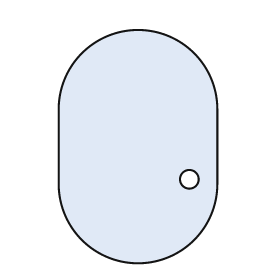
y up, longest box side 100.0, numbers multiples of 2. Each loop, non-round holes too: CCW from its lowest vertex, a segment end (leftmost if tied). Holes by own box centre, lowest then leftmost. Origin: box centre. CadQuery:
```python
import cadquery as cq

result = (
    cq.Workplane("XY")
    .moveTo(-34.0, -16.0)
    .threePointArc((0.0, -50.0), (34.0, -16.0))
    .lineTo(34.0, 16.0)
    .threePointArc((0.0, 50.0), (-34.0, 16.0))
    .close()
    .moveTo(22.0, -14.0)
    .circle(4.0)
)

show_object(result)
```